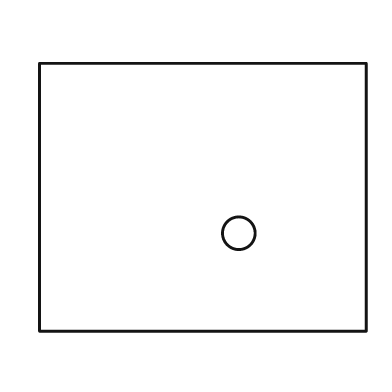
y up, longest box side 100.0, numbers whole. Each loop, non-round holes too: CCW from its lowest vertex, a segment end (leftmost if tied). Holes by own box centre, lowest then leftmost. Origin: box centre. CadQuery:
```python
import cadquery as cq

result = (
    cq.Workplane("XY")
    .moveTo(-50.0, -41.0)
    .lineTo(50.0, -41.0)
    .lineTo(50.0, 41.0)
    .lineTo(-50.0, 41.0)
    .close()
    .moveTo(11.0, -11.0)
    .circle(5.0)
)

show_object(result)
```